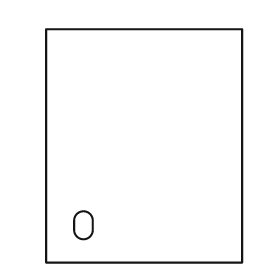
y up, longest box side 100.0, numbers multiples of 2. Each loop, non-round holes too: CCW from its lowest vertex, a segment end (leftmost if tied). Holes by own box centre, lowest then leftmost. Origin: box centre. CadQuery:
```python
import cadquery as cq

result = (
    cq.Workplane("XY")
    .moveTo(-42.0, -50.0)
    .lineTo(42.0, -50.0)
    .lineTo(42.0, 50.0)
    .lineTo(-42.0, 50.0)
    .close()
    .moveTo(-30.0, -36.0)
    .threePointArc((-26.0, -40.0), (-22.0, -36.0))
    .lineTo(-22.0, -32.0)
    .threePointArc((-26.0, -28.0), (-30.0, -32.0))
    .close()
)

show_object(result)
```